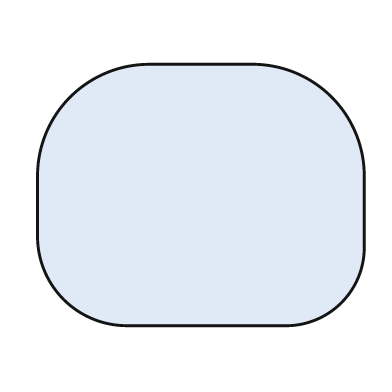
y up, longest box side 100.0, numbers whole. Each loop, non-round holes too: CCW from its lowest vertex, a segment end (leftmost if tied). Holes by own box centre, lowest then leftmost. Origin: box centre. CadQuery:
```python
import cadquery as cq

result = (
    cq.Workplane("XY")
    .moveTo(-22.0, -40.0)
    .lineTo(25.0, -40.0)
    .threePointArc((43.0, -33.0), (50.0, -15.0))
    .lineTo(50.0, 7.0)
    .threePointArc((40.0, 30.0), (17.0, 40.0))
    .lineTo(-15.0, 40.0)
    .threePointArc((-40.0, 30.0), (-50.0, 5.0))
    .lineTo(-50.0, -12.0)
    .threePointArc((-42.0, -32.0), (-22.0, -40.0))
    .close()
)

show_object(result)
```